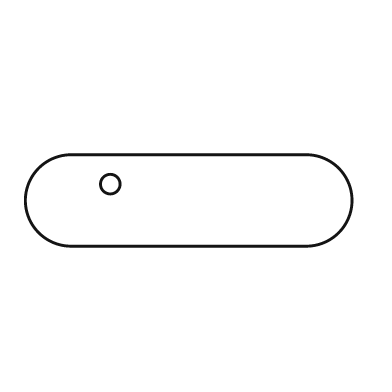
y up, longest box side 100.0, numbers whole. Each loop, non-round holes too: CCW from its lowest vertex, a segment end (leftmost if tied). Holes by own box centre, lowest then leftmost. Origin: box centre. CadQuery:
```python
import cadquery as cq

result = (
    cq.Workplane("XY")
    .moveTo(-36.0, -14.0)
    .lineTo(36.0, -14.0)
    .threePointArc((50.0, 0.0), (36.0, 14.0))
    .lineTo(-36.0, 14.0)
    .threePointArc((-50.0, 0.0), (-36.0, -14.0))
    .close()
    .moveTo(-24.0, 5.0)
    .circle(3.0)
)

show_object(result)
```